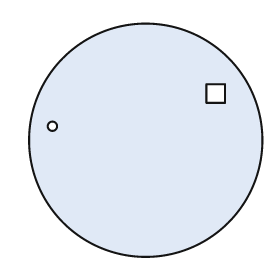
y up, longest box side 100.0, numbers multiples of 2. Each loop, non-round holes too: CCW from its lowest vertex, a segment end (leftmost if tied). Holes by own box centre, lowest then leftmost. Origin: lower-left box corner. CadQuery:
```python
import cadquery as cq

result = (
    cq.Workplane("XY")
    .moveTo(50.0, 50.0)
    .circle(50.0)
    .moveTo(10.0, 56.0)
    .circle(2.0)
    .moveTo(76.0, 66.0)
    .lineTo(84.0, 66.0)
    .lineTo(84.0, 74.0)
    .lineTo(76.0, 74.0)
    .close()
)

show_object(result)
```